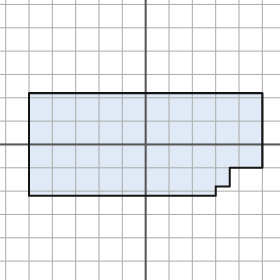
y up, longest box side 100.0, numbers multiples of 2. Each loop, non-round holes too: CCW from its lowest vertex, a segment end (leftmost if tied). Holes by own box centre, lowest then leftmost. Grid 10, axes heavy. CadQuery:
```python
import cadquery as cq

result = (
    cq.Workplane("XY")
    .moveTo(-50.0, -22.0)
    .lineTo(30.0, -22.0)
    .lineTo(30.0, -18.0)
    .lineTo(36.0, -18.0)
    .lineTo(36.0, -10.0)
    .lineTo(50.0, -10.0)
    .lineTo(50.0, 22.0)
    .lineTo(-50.0, 22.0)
    .close()
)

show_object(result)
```